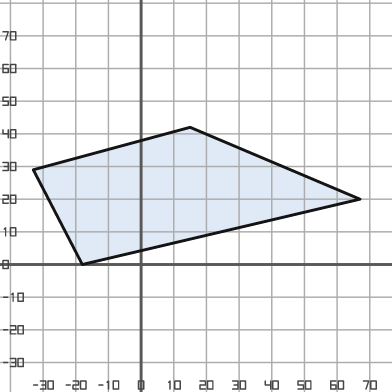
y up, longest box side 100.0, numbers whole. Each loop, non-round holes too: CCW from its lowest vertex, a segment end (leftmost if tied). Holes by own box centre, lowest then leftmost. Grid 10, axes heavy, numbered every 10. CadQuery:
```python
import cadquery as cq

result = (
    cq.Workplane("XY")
    .moveTo(-18.0, 0.0)
    .lineTo(67.0, 20.0)
    .lineTo(15.0, 42.0)
    .lineTo(-33.0, 29.0)
    .close()
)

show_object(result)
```